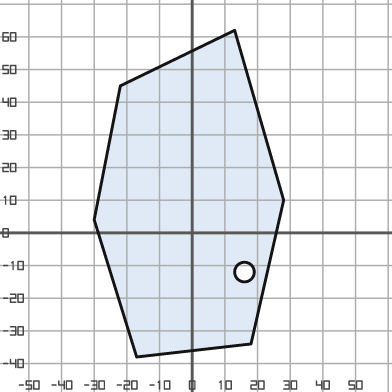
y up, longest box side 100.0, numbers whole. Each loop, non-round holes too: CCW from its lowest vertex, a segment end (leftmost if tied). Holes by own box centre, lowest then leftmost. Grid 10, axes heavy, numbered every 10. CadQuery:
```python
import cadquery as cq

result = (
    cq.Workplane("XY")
    .moveTo(-17.0, -38.0)
    .lineTo(18.0, -34.0)
    .lineTo(28.0, 10.0)
    .lineTo(13.0, 62.0)
    .lineTo(-22.0, 45.0)
    .lineTo(-30.0, 4.0)
    .close()
    .moveTo(16.0, -12.0)
    .circle(3.0)
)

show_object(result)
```